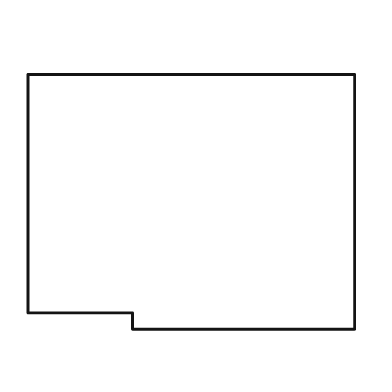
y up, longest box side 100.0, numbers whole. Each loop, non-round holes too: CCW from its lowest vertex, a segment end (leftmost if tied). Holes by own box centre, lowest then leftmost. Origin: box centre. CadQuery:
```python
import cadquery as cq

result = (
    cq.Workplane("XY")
    .moveTo(-18.0, -39.0)
    .lineTo(50.0, -39.0)
    .lineTo(50.0, 39.0)
    .lineTo(-50.0, 39.0)
    .lineTo(-50.0, -34.0)
    .lineTo(-18.0, -34.0)
    .close()
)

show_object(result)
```